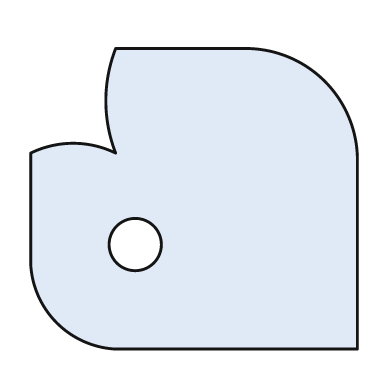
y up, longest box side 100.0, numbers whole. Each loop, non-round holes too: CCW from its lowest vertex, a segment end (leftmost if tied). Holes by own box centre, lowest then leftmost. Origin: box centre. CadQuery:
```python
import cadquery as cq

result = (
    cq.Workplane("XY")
    .moveTo(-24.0, -46.0)
    .lineTo(50.0, -46.0)
    .lineTo(50.0, 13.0)
    .threePointArc((40.0, 36.0), (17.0, 46.0))
    .lineTo(-24.0, 46.0)
    .threePointArc((-27.0, 30.0), (-24.0, 14.0))
    .threePointArc((-37.0, 17.0), (-50.0, 14.0))
    .lineTo(-50.0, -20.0)
    .threePointArc((-42.0, -38.0), (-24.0, -46.0))
    .close()
    .moveTo(-18.0, -14.0)
    .circle(8.0)
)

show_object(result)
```